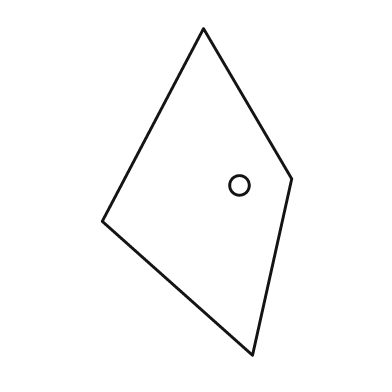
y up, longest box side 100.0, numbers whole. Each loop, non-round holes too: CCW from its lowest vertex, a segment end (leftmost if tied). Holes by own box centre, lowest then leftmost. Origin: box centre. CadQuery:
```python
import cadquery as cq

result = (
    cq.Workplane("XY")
    .moveTo(17.0, -50.0)
    .lineTo(29.0, 4.0)
    .lineTo(2.0, 50.0)
    .lineTo(-29.0, -9.0)
    .close()
    .moveTo(13.0, 2.0)
    .circle(3.0)
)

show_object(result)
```